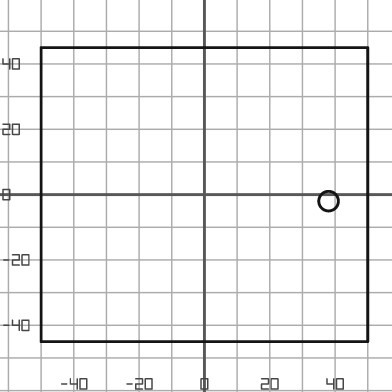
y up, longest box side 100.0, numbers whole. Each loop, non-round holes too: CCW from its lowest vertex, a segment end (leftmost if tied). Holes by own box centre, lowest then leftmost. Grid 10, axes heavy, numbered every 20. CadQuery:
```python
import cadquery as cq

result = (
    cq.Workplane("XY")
    .moveTo(-50.0, -45.0)
    .lineTo(50.0, -45.0)
    .lineTo(50.0, 45.0)
    .lineTo(-50.0, 45.0)
    .close()
    .moveTo(38.0, -2.0)
    .circle(3.0)
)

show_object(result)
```